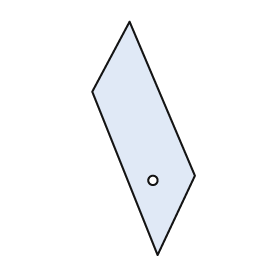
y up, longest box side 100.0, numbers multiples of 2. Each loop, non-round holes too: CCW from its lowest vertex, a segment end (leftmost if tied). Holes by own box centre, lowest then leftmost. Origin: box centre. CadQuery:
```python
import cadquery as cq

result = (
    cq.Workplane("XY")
    .moveTo(6.0, -50.0)
    .lineTo(22.0, -16.0)
    .lineTo(-6.0, 50.0)
    .lineTo(-22.0, 20.0)
    .close()
    .moveTo(4.0, -18.0)
    .circle(2.0)
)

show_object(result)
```